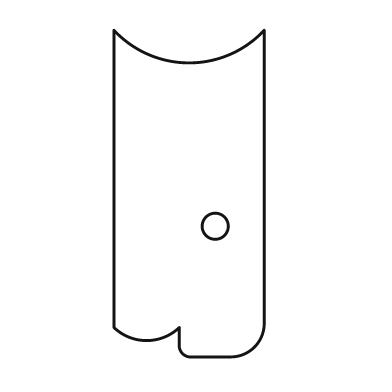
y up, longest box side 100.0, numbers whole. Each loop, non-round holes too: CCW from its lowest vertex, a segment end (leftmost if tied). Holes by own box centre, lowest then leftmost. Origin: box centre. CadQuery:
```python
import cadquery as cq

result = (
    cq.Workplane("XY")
    .moveTo(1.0, -50.0)
    .lineTo(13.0, -50.0)
    .threePointArc((20.0, -47.0), (23.0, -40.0))
    .lineTo(23.0, 50.0)
    .threePointArc((0.0, 40.0), (-23.0, 50.0))
    .lineTo(-23.0, -41.0)
    .threePointArc((-13.0, -45.0), (-3.0, -41.0))
    .lineTo(-3.0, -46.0)
    .threePointArc((-2.0, -49.0), (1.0, -50.0))
    .close()
    .moveTo(8.0, -10.0)
    .circle(4.0)
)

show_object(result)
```